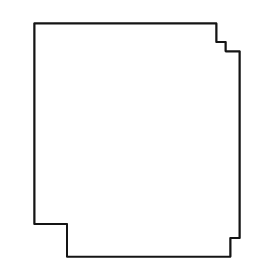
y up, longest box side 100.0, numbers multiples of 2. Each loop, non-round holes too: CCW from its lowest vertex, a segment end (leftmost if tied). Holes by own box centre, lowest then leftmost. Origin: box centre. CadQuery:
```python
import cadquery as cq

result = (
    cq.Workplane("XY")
    .moveTo(-30.0, -50.0)
    .lineTo(40.0, -50.0)
    .lineTo(40.0, -42.0)
    .lineTo(44.0, -42.0)
    .lineTo(44.0, 38.0)
    .lineTo(38.0, 38.0)
    .lineTo(38.0, 42.0)
    .lineTo(34.0, 42.0)
    .lineTo(34.0, 50.0)
    .lineTo(-44.0, 50.0)
    .lineTo(-44.0, -36.0)
    .lineTo(-30.0, -36.0)
    .close()
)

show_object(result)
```